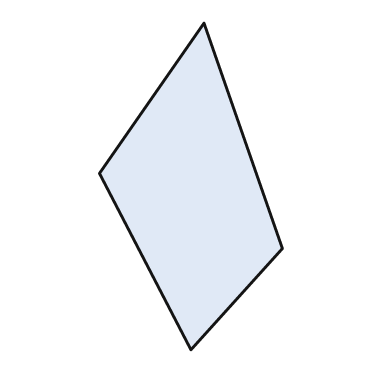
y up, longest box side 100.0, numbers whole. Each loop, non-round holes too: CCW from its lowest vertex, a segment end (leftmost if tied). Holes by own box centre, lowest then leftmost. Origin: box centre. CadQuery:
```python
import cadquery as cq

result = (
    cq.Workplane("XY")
    .moveTo(0.0, -50.0)
    .lineTo(28.0, -19.0)
    .lineTo(4.0, 50.0)
    .lineTo(-28.0, 4.0)
    .close()
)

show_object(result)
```